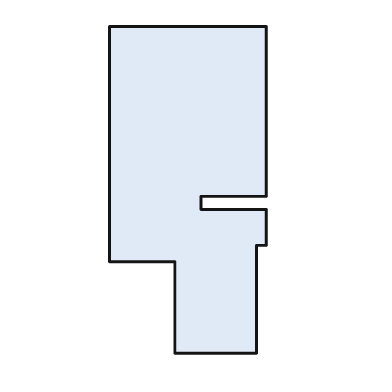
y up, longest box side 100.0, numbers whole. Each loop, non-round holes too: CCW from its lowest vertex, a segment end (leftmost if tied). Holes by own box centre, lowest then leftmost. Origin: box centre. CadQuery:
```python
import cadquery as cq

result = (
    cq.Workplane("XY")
    .moveTo(-4.0, -50.0)
    .lineTo(21.0, -50.0)
    .lineTo(21.0, -17.0)
    .lineTo(24.0, -17.0)
    .lineTo(24.0, -6.0)
    .lineTo(4.0, -6.0)
    .lineTo(4.0, -2.0)
    .lineTo(24.0, -2.0)
    .lineTo(24.0, 50.0)
    .lineTo(-24.0, 50.0)
    .lineTo(-24.0, -22.0)
    .lineTo(-4.0, -22.0)
    .close()
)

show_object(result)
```